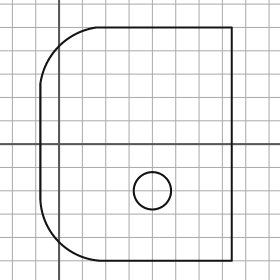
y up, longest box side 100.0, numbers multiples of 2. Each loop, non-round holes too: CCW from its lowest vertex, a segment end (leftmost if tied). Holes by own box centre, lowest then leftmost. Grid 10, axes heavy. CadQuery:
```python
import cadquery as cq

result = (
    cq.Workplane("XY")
    .moveTo(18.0, -50.0)
    .lineTo(74.0, -50.0)
    .lineTo(74.0, 50.0)
    .lineTo(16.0, 50.0)
    .threePointArc((0.0, 42.0), (-8.0, 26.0))
    .lineTo(-8.0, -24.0)
    .threePointArc((0.0, -42.0), (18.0, -50.0))
    .close()
    .moveTo(40.0, -20.0)
    .circle(8.0)
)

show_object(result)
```